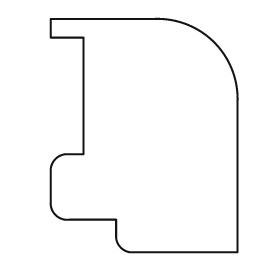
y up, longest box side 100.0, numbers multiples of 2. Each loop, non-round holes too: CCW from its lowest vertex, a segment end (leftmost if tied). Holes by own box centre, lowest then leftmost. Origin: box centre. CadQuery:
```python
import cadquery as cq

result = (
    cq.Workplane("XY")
    .moveTo(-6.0, -50.0)
    .lineTo(40.0, -50.0)
    .lineTo(40.0, 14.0)
    .threePointArc((30.0, 40.0), (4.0, 50.0))
    .lineTo(-40.0, 50.0)
    .lineTo(-40.0, 42.0)
    .lineTo(-26.0, 42.0)
    .lineTo(-26.0, -8.0)
    .lineTo(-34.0, -8.0)
    .threePointArc((-38.0, -10.0), (-40.0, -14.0))
    .lineTo(-40.0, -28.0)
    .threePointArc((-38.0, -34.0), (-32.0, -36.0))
    .lineTo(-12.0, -36.0)
    .lineTo(-12.0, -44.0)
    .threePointArc((-10.0, -48.0), (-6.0, -50.0))
    .close()
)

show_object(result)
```